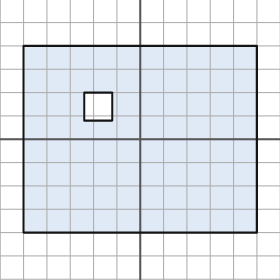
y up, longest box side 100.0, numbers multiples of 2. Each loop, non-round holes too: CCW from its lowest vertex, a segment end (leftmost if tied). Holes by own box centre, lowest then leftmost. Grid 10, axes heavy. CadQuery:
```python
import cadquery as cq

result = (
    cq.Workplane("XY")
    .moveTo(-50.0, -40.0)
    .lineTo(50.0, -40.0)
    .lineTo(50.0, 40.0)
    .lineTo(-50.0, 40.0)
    .close()
    .moveTo(-24.0, 8.0)
    .lineTo(-12.0, 8.0)
    .lineTo(-12.0, 20.0)
    .lineTo(-24.0, 20.0)
    .close()
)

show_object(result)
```